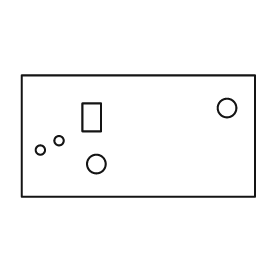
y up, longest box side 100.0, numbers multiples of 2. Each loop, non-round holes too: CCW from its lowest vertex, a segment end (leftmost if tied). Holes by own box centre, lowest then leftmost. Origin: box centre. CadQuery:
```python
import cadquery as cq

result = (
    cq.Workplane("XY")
    .moveTo(-50.0, -26.0)
    .lineTo(50.0, -26.0)
    .lineTo(50.0, 26.0)
    .lineTo(-50.0, 26.0)
    .close()
    .moveTo(-18.0, -12.0)
    .circle(4.0)
    .moveTo(-42.0, -6.0)
    .circle(2.0)
    .moveTo(-34.0, -2.0)
    .circle(2.0)
    .moveTo(-24.0, 2.0)
    .lineTo(-16.0, 2.0)
    .lineTo(-16.0, 14.0)
    .lineTo(-24.0, 14.0)
    .close()
    .moveTo(38.0, 12.0)
    .circle(4.0)
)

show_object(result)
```